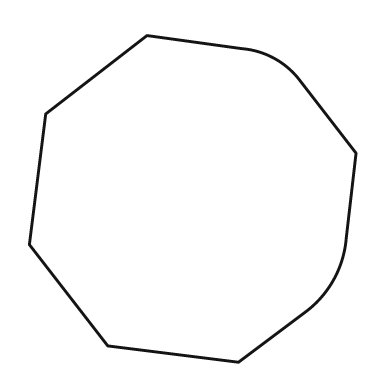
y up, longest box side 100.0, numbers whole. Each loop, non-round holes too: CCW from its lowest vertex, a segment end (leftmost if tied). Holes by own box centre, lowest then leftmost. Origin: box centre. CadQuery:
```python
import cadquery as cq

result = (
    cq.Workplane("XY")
    .moveTo(14.0, -50.0)
    .lineTo(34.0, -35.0)
    .threePointArc((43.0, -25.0), (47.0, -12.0))
    .lineTo(50.0, 14.0)
    .lineTo(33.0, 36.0)
    .threePointArc((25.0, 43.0), (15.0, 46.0))
    .lineTo(-14.0, 50.0)
    .lineTo(-45.0, 26.0)
    .lineTo(-50.0, -14.0)
    .lineTo(-26.0, -45.0)
    .close()
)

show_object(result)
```